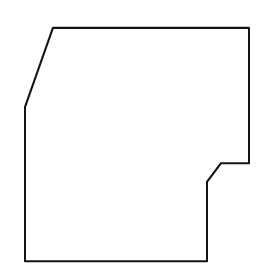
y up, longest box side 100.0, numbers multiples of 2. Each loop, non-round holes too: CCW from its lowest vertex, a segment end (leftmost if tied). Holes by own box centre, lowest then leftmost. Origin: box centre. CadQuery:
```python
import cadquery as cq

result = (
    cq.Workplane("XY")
    .moveTo(-48.0, -50.0)
    .lineTo(30.0, -50.0)
    .lineTo(30.0, -16.0)
    .lineTo(36.0, -8.0)
    .lineTo(48.0, -8.0)
    .lineTo(48.0, 50.0)
    .lineTo(-36.0, 50.0)
    .lineTo(-48.0, 16.0)
    .close()
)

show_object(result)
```